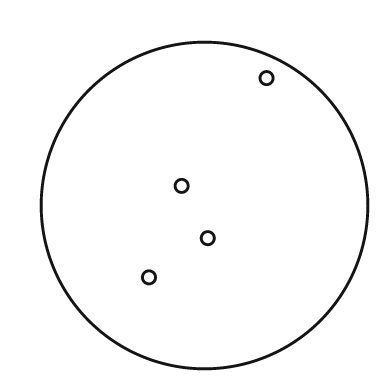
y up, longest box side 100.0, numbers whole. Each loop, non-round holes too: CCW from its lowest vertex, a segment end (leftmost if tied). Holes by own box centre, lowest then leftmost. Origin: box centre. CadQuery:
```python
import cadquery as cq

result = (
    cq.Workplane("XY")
    .moveTo(0.0, 0.0)
    .circle(50.0)
    .moveTo(-17.0, -22.0)
    .circle(2.0)
    .moveTo(1.0, -10.0)
    .circle(2.0)
    .moveTo(-7.0, 6.0)
    .circle(2.0)
    .moveTo(19.0, 39.0)
    .circle(2.0)
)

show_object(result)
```